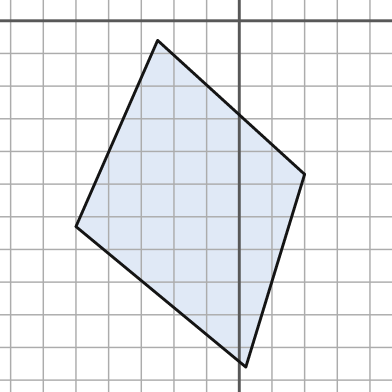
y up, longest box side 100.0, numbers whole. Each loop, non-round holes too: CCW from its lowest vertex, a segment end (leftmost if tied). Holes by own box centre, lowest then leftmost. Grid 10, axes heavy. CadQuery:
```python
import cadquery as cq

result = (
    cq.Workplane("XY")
    .moveTo(2.0, -106.0)
    .lineTo(20.0, -47.0)
    .lineTo(-25.0, -6.0)
    .lineTo(-50.0, -63.0)
    .close()
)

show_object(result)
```